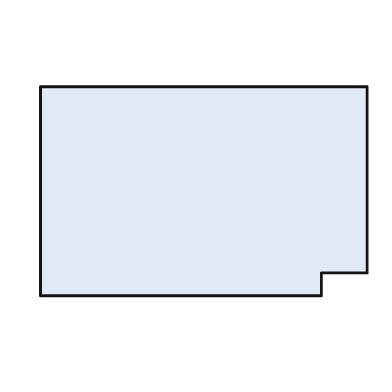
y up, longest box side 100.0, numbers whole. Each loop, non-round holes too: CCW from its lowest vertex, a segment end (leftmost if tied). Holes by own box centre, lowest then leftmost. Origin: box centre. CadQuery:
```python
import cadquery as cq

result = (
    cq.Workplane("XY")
    .moveTo(-50.0, -32.0)
    .lineTo(36.0, -32.0)
    .lineTo(36.0, -25.0)
    .lineTo(50.0, -25.0)
    .lineTo(50.0, 32.0)
    .lineTo(-50.0, 32.0)
    .close()
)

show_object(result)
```